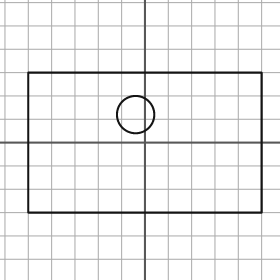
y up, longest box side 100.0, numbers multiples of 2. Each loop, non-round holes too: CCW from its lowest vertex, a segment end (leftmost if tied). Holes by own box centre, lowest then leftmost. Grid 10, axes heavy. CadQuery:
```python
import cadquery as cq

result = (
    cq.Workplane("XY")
    .moveTo(-50.0, -30.0)
    .lineTo(50.0, -30.0)
    .lineTo(50.0, 30.0)
    .lineTo(-50.0, 30.0)
    .close()
    .moveTo(-4.0, 12.0)
    .circle(8.0)
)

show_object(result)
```